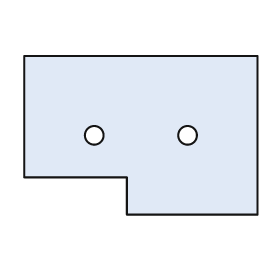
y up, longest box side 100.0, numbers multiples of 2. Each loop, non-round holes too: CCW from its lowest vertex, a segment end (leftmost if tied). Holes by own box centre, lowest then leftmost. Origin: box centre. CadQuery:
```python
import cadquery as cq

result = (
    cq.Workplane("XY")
    .moveTo(-6.0, -34.0)
    .lineTo(50.0, -34.0)
    .lineTo(50.0, 34.0)
    .lineTo(-50.0, 34.0)
    .lineTo(-50.0, -18.0)
    .lineTo(-6.0, -18.0)
    .close()
    .moveTo(-20.0, 0.0)
    .circle(4.0)
    .moveTo(20.0, 0.0)
    .circle(4.0)
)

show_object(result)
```